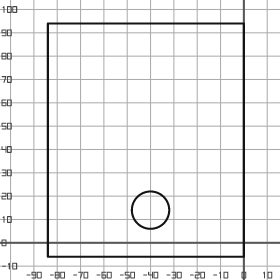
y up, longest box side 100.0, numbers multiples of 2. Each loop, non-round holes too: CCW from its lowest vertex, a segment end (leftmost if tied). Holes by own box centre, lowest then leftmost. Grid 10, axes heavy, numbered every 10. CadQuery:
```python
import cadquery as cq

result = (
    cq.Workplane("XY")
    .moveTo(-84.0, -6.0)
    .lineTo(0.0, -6.0)
    .lineTo(0.0, 94.0)
    .lineTo(-84.0, 94.0)
    .close()
    .moveTo(-40.0, 14.0)
    .circle(8.0)
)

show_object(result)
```